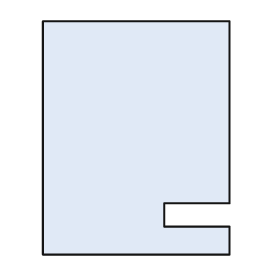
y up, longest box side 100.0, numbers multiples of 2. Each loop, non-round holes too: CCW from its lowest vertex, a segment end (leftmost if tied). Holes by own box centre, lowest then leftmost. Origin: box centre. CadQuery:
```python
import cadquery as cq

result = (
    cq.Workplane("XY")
    .moveTo(-40.0, -50.0)
    .lineTo(40.0, -50.0)
    .lineTo(40.0, -38.0)
    .lineTo(12.0, -38.0)
    .lineTo(12.0, -28.0)
    .lineTo(40.0, -28.0)
    .lineTo(40.0, 50.0)
    .lineTo(-40.0, 50.0)
    .close()
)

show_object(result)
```